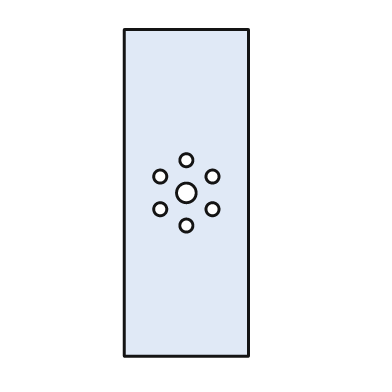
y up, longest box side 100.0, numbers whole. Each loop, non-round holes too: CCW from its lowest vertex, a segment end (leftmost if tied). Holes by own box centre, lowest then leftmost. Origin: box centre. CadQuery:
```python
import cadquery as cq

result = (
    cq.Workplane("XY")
    .moveTo(-19.0, -50.0)
    .lineTo(19.0, -50.0)
    .lineTo(19.0, 50.0)
    .lineTo(-19.0, 50.0)
    .close()
    .moveTo(0.0, -10.0)
    .circle(2.0)
    .moveTo(-8.0, -5.0)
    .circle(2.0)
    .moveTo(8.0, -5.0)
    .circle(2.0)
    .moveTo(0.0, 0.0)
    .circle(3.0)
    .moveTo(-8.0, 5.0)
    .circle(2.0)
    .moveTo(8.0, 5.0)
    .circle(2.0)
    .moveTo(0.0, 10.0)
    .circle(2.0)
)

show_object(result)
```